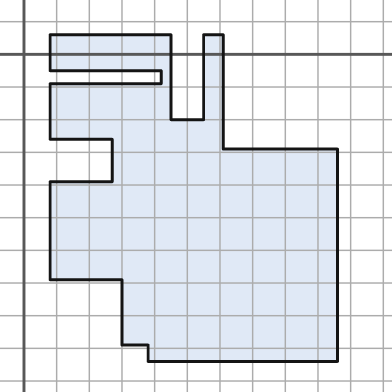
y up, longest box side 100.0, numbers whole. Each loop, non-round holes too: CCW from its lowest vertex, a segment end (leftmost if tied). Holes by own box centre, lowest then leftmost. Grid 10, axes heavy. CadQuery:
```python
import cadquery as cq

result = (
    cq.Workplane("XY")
    .moveTo(38.0, -94.0)
    .lineTo(96.0, -94.0)
    .lineTo(96.0, -29.0)
    .lineTo(61.0, -29.0)
    .lineTo(61.0, 6.0)
    .lineTo(55.0, 6.0)
    .lineTo(55.0, -20.0)
    .lineTo(45.0, -20.0)
    .lineTo(45.0, 6.0)
    .lineTo(8.0, 6.0)
    .lineTo(8.0, -5.0)
    .lineTo(42.0, -5.0)
    .lineTo(42.0, -9.0)
    .lineTo(8.0, -9.0)
    .lineTo(8.0, -26.0)
    .lineTo(27.0, -26.0)
    .lineTo(27.0, -39.0)
    .lineTo(8.0, -39.0)
    .lineTo(8.0, -69.0)
    .lineTo(30.0, -69.0)
    .lineTo(30.0, -89.0)
    .lineTo(38.0, -89.0)
    .close()
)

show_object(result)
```